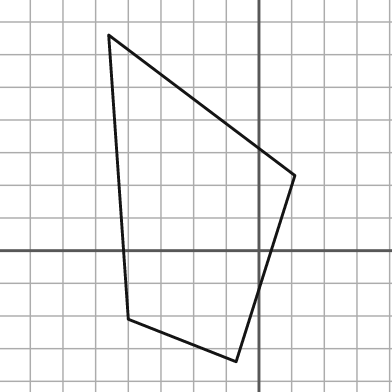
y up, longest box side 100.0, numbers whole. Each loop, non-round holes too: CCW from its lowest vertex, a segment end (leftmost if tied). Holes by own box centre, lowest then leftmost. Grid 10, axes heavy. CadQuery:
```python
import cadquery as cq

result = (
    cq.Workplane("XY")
    .moveTo(-7.0, -34.0)
    .lineTo(11.0, 23.0)
    .lineTo(-46.0, 66.0)
    .lineTo(-40.0, -21.0)
    .close()
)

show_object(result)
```